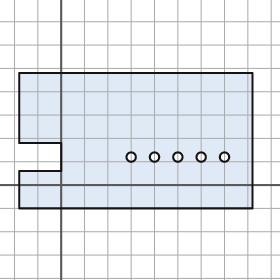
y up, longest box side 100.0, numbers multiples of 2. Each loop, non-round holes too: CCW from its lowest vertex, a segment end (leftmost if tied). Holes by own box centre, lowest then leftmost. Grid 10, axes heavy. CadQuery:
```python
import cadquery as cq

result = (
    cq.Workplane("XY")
    .moveTo(-18.0, -10.0)
    .lineTo(82.0, -10.0)
    .lineTo(82.0, 48.0)
    .lineTo(-18.0, 48.0)
    .lineTo(-18.0, 18.0)
    .lineTo(0.0, 18.0)
    .lineTo(0.0, 6.0)
    .lineTo(-18.0, 6.0)
    .close()
    .moveTo(30.0, 12.0)
    .circle(2.0)
    .moveTo(40.0, 12.0)
    .circle(2.0)
    .moveTo(50.0, 12.0)
    .circle(2.0)
    .moveTo(60.0, 12.0)
    .circle(2.0)
    .moveTo(70.0, 12.0)
    .circle(2.0)
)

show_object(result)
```